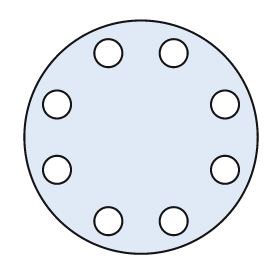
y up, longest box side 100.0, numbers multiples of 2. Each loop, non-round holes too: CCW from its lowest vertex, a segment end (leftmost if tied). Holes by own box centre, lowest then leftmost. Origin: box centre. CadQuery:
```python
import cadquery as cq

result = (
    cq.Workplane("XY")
    .moveTo(0.0, 0.0)
    .circle(50.0)
    .moveTo(-14.0, -36.0)
    .circle(6.0)
    .moveTo(14.0, -36.0)
    .circle(6.0)
    .moveTo(-36.0, -14.0)
    .circle(6.0)
    .moveTo(36.0, -14.0)
    .circle(6.0)
    .moveTo(-36.0, 14.0)
    .circle(6.0)
    .moveTo(36.0, 14.0)
    .circle(6.0)
    .moveTo(-14.0, 36.0)
    .circle(6.0)
    .moveTo(14.0, 36.0)
    .circle(6.0)
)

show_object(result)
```